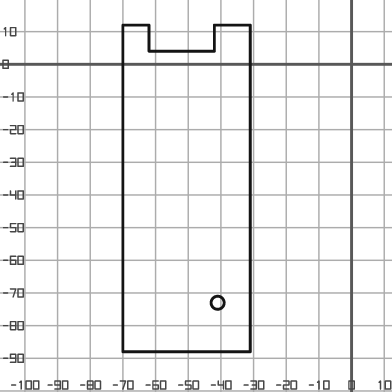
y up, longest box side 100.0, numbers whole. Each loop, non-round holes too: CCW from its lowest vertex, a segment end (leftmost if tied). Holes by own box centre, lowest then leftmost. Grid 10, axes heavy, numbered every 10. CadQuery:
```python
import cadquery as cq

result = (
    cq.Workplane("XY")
    .moveTo(-70.0, -88.0)
    .lineTo(-31.0, -88.0)
    .lineTo(-31.0, 12.0)
    .lineTo(-42.0, 12.0)
    .lineTo(-42.0, 4.0)
    .lineTo(-62.0, 4.0)
    .lineTo(-62.0, 12.0)
    .lineTo(-70.0, 12.0)
    .close()
    .moveTo(-41.0, -73.0)
    .circle(2.0)
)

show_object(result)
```